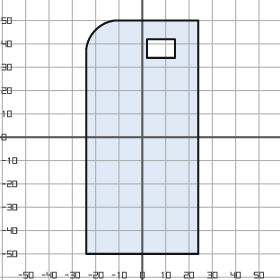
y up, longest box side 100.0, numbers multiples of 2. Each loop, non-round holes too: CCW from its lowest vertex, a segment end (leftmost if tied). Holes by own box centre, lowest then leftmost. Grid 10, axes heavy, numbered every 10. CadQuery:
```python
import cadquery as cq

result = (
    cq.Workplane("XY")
    .moveTo(-24.0, -50.0)
    .lineTo(24.0, -50.0)
    .lineTo(24.0, 50.0)
    .lineTo(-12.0, 50.0)
    .threePointArc((-20.0, 46.0), (-24.0, 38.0))
    .close()
    .moveTo(2.0, 34.0)
    .lineTo(14.0, 34.0)
    .lineTo(14.0, 42.0)
    .lineTo(2.0, 42.0)
    .close()
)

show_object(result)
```